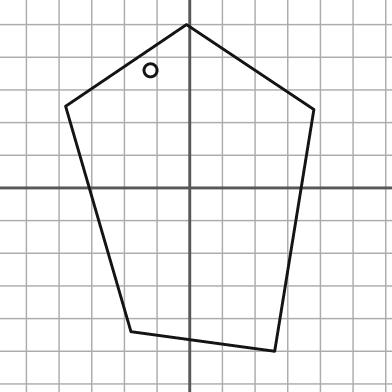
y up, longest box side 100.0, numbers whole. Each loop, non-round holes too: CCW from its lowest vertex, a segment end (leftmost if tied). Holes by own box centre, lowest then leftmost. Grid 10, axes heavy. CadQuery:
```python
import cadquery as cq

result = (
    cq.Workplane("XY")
    .moveTo(26.0, -50.0)
    .lineTo(38.0, 24.0)
    .lineTo(-1.0, 50.0)
    .lineTo(-38.0, 25.0)
    .lineTo(-18.0, -44.0)
    .close()
    .moveTo(-12.0, 36.0)
    .circle(2.0)
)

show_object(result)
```